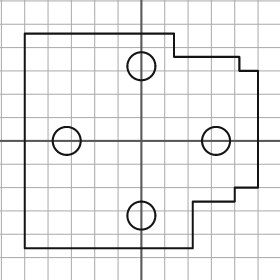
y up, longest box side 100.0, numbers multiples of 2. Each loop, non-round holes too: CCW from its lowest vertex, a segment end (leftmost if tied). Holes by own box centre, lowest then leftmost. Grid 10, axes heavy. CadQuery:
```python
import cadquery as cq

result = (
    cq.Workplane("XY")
    .moveTo(-50.0, -46.0)
    .lineTo(22.0, -46.0)
    .lineTo(22.0, -26.0)
    .lineTo(40.0, -26.0)
    .lineTo(40.0, -20.0)
    .lineTo(50.0, -20.0)
    .lineTo(50.0, 30.0)
    .lineTo(42.0, 30.0)
    .lineTo(42.0, 36.0)
    .lineTo(14.0, 36.0)
    .lineTo(14.0, 46.0)
    .lineTo(-50.0, 46.0)
    .close()
    .moveTo(0.0, -32.0)
    .circle(6.0)
    .moveTo(-32.0, 0.0)
    .circle(6.0)
    .moveTo(32.0, 0.0)
    .circle(6.0)
    .moveTo(0.0, 32.0)
    .circle(6.0)
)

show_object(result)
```